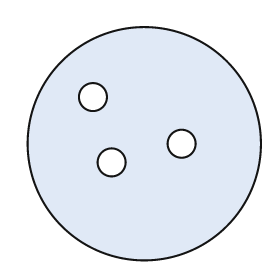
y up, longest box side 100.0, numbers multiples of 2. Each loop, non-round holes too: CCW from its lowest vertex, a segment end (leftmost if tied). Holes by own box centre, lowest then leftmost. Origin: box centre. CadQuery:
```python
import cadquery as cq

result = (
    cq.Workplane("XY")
    .moveTo(0.0, 0.0)
    .circle(50.0)
    .moveTo(-14.0, -8.0)
    .circle(6.0)
    .moveTo(16.0, 0.0)
    .circle(6.0)
    .moveTo(-22.0, 20.0)
    .circle(6.0)
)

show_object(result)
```